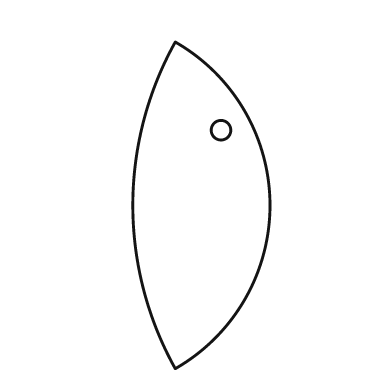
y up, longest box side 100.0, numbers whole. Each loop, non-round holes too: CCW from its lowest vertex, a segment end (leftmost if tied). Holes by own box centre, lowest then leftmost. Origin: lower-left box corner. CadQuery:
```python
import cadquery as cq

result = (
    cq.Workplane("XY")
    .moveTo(13.0, 0.0)
    .threePointArc((42.0, 50.0), (13.0, 100.0))
    .threePointArc((0.0, 50.0), (13.0, 0.0))
    .close()
    .moveTo(27.0, 73.0)
    .circle(3.0)
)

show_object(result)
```